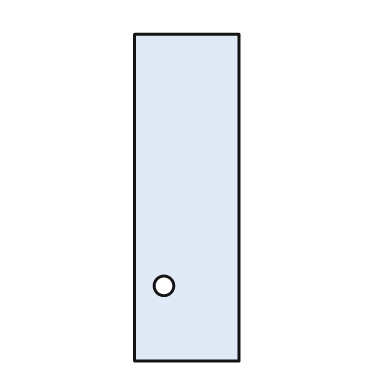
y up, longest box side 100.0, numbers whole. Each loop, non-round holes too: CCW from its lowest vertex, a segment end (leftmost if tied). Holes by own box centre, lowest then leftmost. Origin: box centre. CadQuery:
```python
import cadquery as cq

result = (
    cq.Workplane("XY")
    .moveTo(-16.0, -50.0)
    .lineTo(16.0, -50.0)
    .lineTo(16.0, 50.0)
    .lineTo(-16.0, 50.0)
    .close()
    .moveTo(-7.0, -27.0)
    .circle(3.0)
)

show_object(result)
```